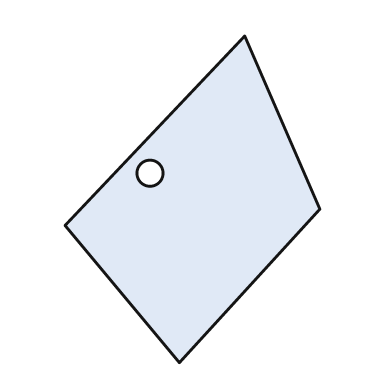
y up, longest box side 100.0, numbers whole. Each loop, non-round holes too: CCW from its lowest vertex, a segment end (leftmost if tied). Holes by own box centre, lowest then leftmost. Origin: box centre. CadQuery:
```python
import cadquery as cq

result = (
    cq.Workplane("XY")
    .moveTo(-4.0, -50.0)
    .lineTo(39.0, -3.0)
    .lineTo(16.0, 50.0)
    .lineTo(-39.0, -8.0)
    .close()
    .moveTo(-13.0, 8.0)
    .circle(4.0)
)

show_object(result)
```